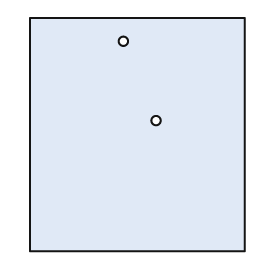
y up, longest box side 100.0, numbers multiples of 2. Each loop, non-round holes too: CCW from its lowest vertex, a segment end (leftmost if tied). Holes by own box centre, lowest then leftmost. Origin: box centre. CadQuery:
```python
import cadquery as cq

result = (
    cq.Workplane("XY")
    .moveTo(-46.0, -50.0)
    .lineTo(46.0, -50.0)
    .lineTo(46.0, 50.0)
    .lineTo(-46.0, 50.0)
    .close()
    .moveTo(8.0, 6.0)
    .circle(2.0)
    .moveTo(-6.0, 40.0)
    .circle(2.0)
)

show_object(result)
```